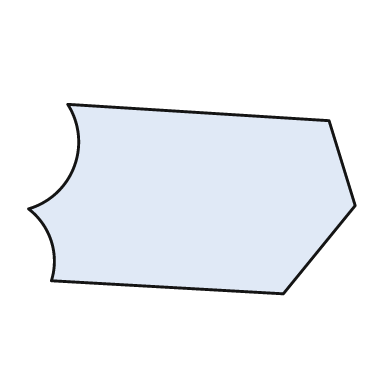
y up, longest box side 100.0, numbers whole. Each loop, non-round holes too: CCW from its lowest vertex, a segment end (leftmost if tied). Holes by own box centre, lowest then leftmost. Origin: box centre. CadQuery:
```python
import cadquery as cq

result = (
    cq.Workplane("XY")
    .moveTo(28.0, -29.0)
    .lineTo(50.0, -2.0)
    .lineTo(42.0, 24.0)
    .lineTo(-38.0, 29.0)
    .threePointArc((-36.0, 10.0), (-50.0, -3.0))
    .threePointArc((-43.0, -13.0), (-43.0, -25.0))
    .close()
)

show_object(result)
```